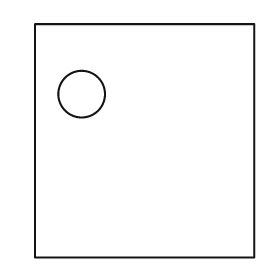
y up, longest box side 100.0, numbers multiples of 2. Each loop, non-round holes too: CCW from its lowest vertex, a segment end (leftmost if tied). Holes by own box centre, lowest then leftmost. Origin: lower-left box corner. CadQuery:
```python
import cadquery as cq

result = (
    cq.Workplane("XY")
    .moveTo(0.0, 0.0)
    .lineTo(94.0, 0.0)
    .lineTo(94.0, 100.0)
    .lineTo(0.0, 100.0)
    .close()
    .moveTo(20.0, 70.0)
    .circle(10.0)
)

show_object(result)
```